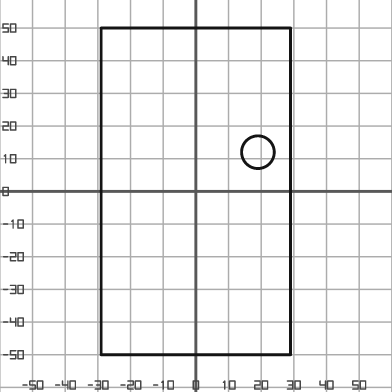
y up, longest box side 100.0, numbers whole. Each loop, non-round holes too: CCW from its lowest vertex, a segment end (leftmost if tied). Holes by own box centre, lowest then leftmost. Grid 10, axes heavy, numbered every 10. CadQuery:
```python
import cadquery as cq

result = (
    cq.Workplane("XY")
    .moveTo(-29.0, -50.0)
    .lineTo(29.0, -50.0)
    .lineTo(29.0, 50.0)
    .lineTo(-29.0, 50.0)
    .close()
    .moveTo(19.0, 12.0)
    .circle(5.0)
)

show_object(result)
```